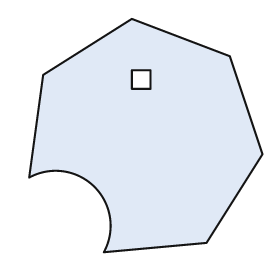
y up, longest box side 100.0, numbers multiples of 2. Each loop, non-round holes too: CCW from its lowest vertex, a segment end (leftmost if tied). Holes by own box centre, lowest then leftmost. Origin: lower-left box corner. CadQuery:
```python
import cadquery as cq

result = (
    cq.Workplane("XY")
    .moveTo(32.0, 0.0)
    .lineTo(76.0, 4.0)
    .lineTo(100.0, 42.0)
    .lineTo(86.0, 84.0)
    .lineTo(44.0, 100.0)
    .lineTo(6.0, 76.0)
    .lineTo(0.0, 32.0)
    .threePointArc((28.0, 28.0), (32.0, 0.0))
    .close()
    .moveTo(44.0, 70.0)
    .lineTo(52.0, 70.0)
    .lineTo(52.0, 78.0)
    .lineTo(44.0, 78.0)
    .close()
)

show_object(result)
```